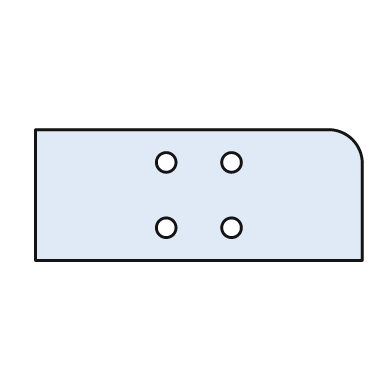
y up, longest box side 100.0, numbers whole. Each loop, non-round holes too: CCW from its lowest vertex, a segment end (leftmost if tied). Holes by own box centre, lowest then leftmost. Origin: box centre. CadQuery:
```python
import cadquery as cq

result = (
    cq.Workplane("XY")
    .moveTo(-50.0, -20.0)
    .lineTo(50.0, -20.0)
    .lineTo(50.0, 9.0)
    .threePointArc((47.0, 17.0), (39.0, 20.0))
    .lineTo(-50.0, 20.0)
    .close()
    .moveTo(-10.0, -10.0)
    .circle(3.0)
    .moveTo(10.0, -10.0)
    .circle(3.0)
    .moveTo(-10.0, 10.0)
    .circle(3.0)
    .moveTo(10.0, 10.0)
    .circle(3.0)
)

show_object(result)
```